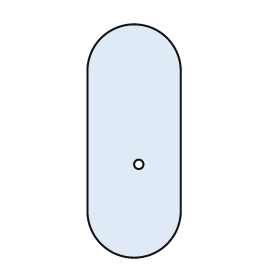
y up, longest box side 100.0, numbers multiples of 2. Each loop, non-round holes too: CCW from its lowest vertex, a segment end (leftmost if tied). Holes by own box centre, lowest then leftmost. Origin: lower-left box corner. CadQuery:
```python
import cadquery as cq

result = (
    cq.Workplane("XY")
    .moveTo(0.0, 20.0)
    .threePointArc((20.0, 0.0), (40.0, 20.0))
    .lineTo(40.0, 80.0)
    .threePointArc((20.0, 100.0), (0.0, 80.0))
    .close()
    .moveTo(22.0, 40.0)
    .circle(2.0)
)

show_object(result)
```